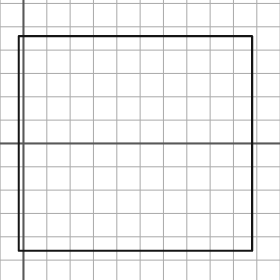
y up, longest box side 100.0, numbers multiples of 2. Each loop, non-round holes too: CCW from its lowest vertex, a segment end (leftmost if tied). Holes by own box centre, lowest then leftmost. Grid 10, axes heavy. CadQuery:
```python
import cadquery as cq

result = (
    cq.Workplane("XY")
    .moveTo(-2.0, -46.0)
    .lineTo(98.0, -46.0)
    .lineTo(98.0, 46.0)
    .lineTo(-2.0, 46.0)
    .close()
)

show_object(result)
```